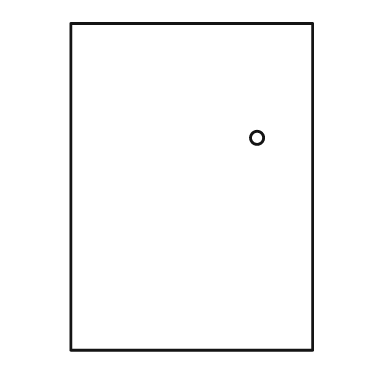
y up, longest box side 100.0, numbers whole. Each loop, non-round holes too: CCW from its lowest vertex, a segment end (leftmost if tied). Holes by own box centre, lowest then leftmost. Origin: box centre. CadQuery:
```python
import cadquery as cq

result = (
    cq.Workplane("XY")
    .moveTo(-37.0, -50.0)
    .lineTo(37.0, -50.0)
    .lineTo(37.0, 50.0)
    .lineTo(-37.0, 50.0)
    .close()
    .moveTo(20.0, 15.0)
    .circle(2.0)
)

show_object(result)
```